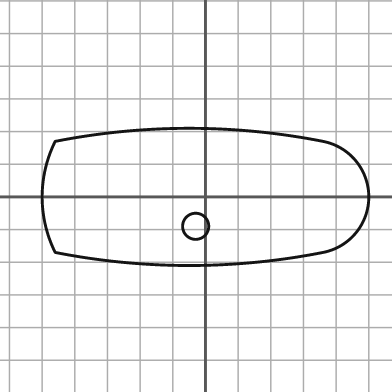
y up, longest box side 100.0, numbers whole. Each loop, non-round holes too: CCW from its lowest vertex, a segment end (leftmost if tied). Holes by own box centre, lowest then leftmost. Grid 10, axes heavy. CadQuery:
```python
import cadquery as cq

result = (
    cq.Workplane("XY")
    .moveTo(-46.0, -17.0)
    .threePointArc((-5.0, -21.0), (36.0, -17.0))
    .threePointArc((50.0, 0.0), (36.0, 17.0))
    .threePointArc((-5.0, 21.0), (-46.0, 17.0))
    .threePointArc((-50.0, 0.0), (-46.0, -17.0))
    .close()
    .moveTo(-3.0, -9.0)
    .circle(4.0)
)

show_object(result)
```